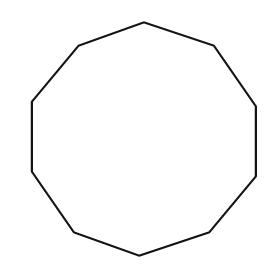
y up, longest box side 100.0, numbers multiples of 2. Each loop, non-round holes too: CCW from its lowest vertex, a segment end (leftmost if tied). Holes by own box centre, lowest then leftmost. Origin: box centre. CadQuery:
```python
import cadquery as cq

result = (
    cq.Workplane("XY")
    .moveTo(-2.0, -50.0)
    .lineTo(28.0, -40.0)
    .lineTo(48.0, -16.0)
    .lineTo(48.0, 14.0)
    .lineTo(30.0, 40.0)
    .lineTo(0.0, 50.0)
    .lineTo(-28.0, 40.0)
    .lineTo(-48.0, 16.0)
    .lineTo(-48.0, -14.0)
    .lineTo(-30.0, -40.0)
    .close()
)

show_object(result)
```